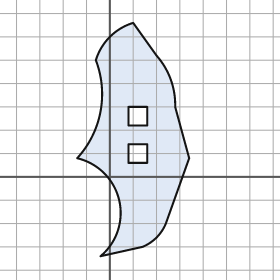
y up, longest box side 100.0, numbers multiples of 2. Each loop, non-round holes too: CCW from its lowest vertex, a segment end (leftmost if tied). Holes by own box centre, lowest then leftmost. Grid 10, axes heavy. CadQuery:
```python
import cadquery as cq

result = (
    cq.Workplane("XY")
    .moveTo(-4.0, -34.0)
    .lineTo(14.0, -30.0)
    .threePointArc((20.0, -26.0), (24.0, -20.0))
    .lineTo(34.0, 8.0)
    .lineTo(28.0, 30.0)
    .threePointArc((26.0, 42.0), (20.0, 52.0))
    .lineTo(10.0, 66.0)
    .threePointArc((0.0, 60.0), (-6.0, 50.0))
    .threePointArc((-4.0, 28.0), (-14.0, 8.0))
    .threePointArc((4.0, -10.0), (-4.0, -34.0))
    .close()
    .moveTo(8.0, 6.0)
    .lineTo(16.0, 6.0)
    .lineTo(16.0, 14.0)
    .lineTo(8.0, 14.0)
    .close()
    .moveTo(8.0, 22.0)
    .lineTo(16.0, 22.0)
    .lineTo(16.0, 30.0)
    .lineTo(8.0, 30.0)
    .close()
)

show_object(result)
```